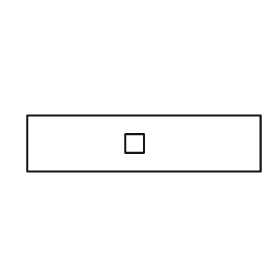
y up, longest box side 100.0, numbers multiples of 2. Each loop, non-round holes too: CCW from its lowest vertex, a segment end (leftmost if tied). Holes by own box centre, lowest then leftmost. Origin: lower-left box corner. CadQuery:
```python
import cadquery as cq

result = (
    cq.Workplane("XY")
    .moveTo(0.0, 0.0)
    .lineTo(100.0, 0.0)
    .lineTo(100.0, 24.0)
    .lineTo(0.0, 24.0)
    .close()
    .moveTo(42.0, 8.0)
    .lineTo(50.0, 8.0)
    .lineTo(50.0, 16.0)
    .lineTo(42.0, 16.0)
    .close()
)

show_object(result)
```